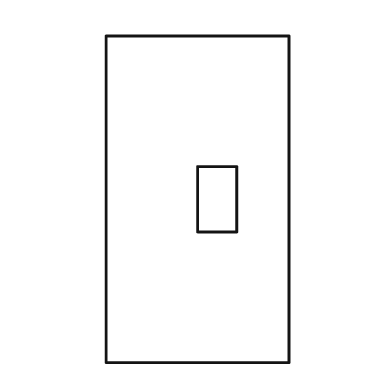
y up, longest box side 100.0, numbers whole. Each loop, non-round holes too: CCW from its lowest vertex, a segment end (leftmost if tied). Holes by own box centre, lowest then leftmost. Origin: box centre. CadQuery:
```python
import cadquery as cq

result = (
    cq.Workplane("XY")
    .moveTo(-28.0, -50.0)
    .lineTo(28.0, -50.0)
    .lineTo(28.0, 50.0)
    .lineTo(-28.0, 50.0)
    .close()
    .moveTo(0.0, -10.0)
    .lineTo(12.0, -10.0)
    .lineTo(12.0, 10.0)
    .lineTo(0.0, 10.0)
    .close()
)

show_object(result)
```